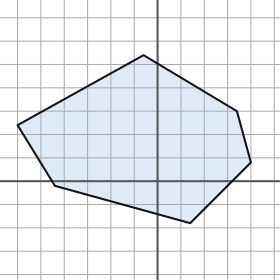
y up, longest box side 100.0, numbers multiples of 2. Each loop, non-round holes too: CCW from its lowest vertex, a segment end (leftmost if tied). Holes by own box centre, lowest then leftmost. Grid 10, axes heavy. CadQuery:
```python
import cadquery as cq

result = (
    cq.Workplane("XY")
    .moveTo(14.0, -18.0)
    .lineTo(40.0, 8.0)
    .lineTo(34.0, 30.0)
    .lineTo(-6.0, 54.0)
    .lineTo(-60.0, 24.0)
    .lineTo(-44.0, -2.0)
    .close()
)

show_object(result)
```